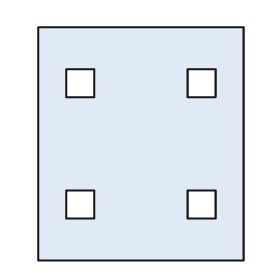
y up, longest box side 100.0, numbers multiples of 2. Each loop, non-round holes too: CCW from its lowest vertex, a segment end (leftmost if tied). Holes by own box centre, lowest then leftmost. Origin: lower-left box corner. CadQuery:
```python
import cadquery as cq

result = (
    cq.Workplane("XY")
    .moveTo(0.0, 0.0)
    .lineTo(88.0, 0.0)
    .lineTo(88.0, 100.0)
    .lineTo(0.0, 100.0)
    .close()
    .moveTo(12.0, 18.0)
    .lineTo(24.0, 18.0)
    .lineTo(24.0, 30.0)
    .lineTo(12.0, 30.0)
    .close()
    .moveTo(64.0, 18.0)
    .lineTo(76.0, 18.0)
    .lineTo(76.0, 30.0)
    .lineTo(64.0, 30.0)
    .close()
    .moveTo(12.0, 70.0)
    .lineTo(24.0, 70.0)
    .lineTo(24.0, 82.0)
    .lineTo(12.0, 82.0)
    .close()
    .moveTo(64.0, 70.0)
    .lineTo(76.0, 70.0)
    .lineTo(76.0, 82.0)
    .lineTo(64.0, 82.0)
    .close()
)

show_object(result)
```